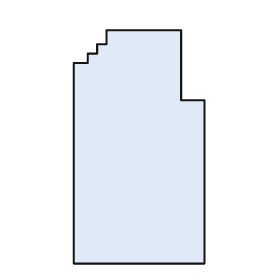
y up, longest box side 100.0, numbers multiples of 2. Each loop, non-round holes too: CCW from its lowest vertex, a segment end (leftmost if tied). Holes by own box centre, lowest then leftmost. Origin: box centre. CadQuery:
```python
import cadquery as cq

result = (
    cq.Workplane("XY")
    .moveTo(-28.0, -50.0)
    .lineTo(28.0, -50.0)
    .lineTo(28.0, 20.0)
    .lineTo(18.0, 20.0)
    .lineTo(18.0, 50.0)
    .lineTo(-14.0, 50.0)
    .lineTo(-14.0, 44.0)
    .lineTo(-18.0, 44.0)
    .lineTo(-18.0, 40.0)
    .lineTo(-22.0, 40.0)
    .lineTo(-22.0, 36.0)
    .lineTo(-28.0, 36.0)
    .close()
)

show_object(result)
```